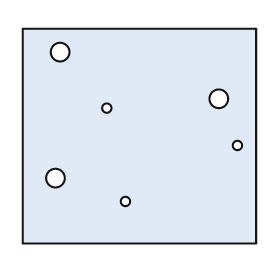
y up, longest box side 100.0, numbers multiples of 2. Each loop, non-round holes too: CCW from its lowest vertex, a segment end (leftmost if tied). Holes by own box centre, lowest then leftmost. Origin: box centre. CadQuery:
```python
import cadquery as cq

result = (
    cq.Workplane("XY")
    .moveTo(-50.0, -46.0)
    .lineTo(50.0, -46.0)
    .lineTo(50.0, 46.0)
    .lineTo(-50.0, 46.0)
    .close()
    .moveTo(-6.0, -28.0)
    .circle(2.0)
    .moveTo(-36.0, -18.0)
    .circle(4.0)
    .moveTo(42.0, -4.0)
    .circle(2.0)
    .moveTo(-14.0, 12.0)
    .circle(2.0)
    .moveTo(34.0, 16.0)
    .circle(4.0)
    .moveTo(-34.0, 36.0)
    .circle(4.0)
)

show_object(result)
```